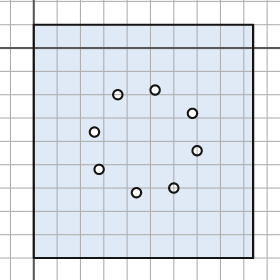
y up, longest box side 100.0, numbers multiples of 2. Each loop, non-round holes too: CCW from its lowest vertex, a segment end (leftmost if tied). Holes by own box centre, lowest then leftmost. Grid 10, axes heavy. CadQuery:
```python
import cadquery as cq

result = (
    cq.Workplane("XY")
    .moveTo(0.0, -90.0)
    .lineTo(94.0, -90.0)
    .lineTo(94.0, 10.0)
    .lineTo(0.0, 10.0)
    .close()
    .moveTo(44.0, -62.0)
    .circle(2.0)
    .moveTo(60.0, -60.0)
    .circle(2.0)
    .moveTo(28.0, -52.0)
    .circle(2.0)
    .moveTo(70.0, -44.0)
    .circle(2.0)
    .moveTo(26.0, -36.0)
    .circle(2.0)
    .moveTo(68.0, -28.0)
    .circle(2.0)
    .moveTo(36.0, -20.0)
    .circle(2.0)
    .moveTo(52.0, -18.0)
    .circle(2.0)
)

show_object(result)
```